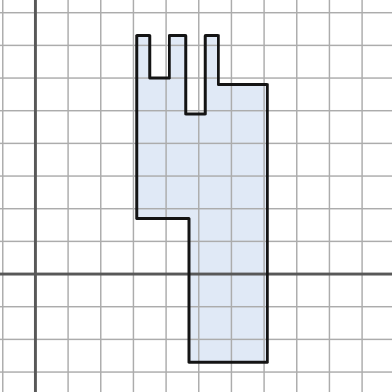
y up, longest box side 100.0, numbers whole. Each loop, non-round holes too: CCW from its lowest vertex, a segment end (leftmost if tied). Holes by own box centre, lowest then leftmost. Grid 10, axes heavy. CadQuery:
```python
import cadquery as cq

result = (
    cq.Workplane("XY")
    .moveTo(47.0, -27.0)
    .lineTo(71.0, -27.0)
    .lineTo(71.0, 58.0)
    .lineTo(56.0, 58.0)
    .lineTo(56.0, 73.0)
    .lineTo(52.0, 73.0)
    .lineTo(52.0, 49.0)
    .lineTo(46.0, 49.0)
    .lineTo(46.0, 73.0)
    .lineTo(41.0, 73.0)
    .lineTo(41.0, 60.0)
    .lineTo(35.0, 60.0)
    .lineTo(35.0, 73.0)
    .lineTo(31.0, 73.0)
    .lineTo(31.0, 17.0)
    .lineTo(47.0, 17.0)
    .close()
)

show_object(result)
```